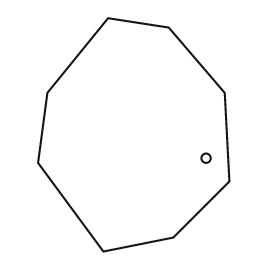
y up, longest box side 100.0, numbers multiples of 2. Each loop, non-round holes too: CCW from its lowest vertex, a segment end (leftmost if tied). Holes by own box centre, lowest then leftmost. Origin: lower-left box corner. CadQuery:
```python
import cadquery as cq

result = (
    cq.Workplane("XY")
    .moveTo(28.0, 0.0)
    .lineTo(58.0, 6.0)
    .lineTo(82.0, 30.0)
    .lineTo(80.0, 68.0)
    .lineTo(56.0, 96.0)
    .lineTo(30.0, 100.0)
    .lineTo(4.0, 68.0)
    .lineTo(0.0, 38.0)
    .close()
    .moveTo(72.0, 40.0)
    .circle(2.0)
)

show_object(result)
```